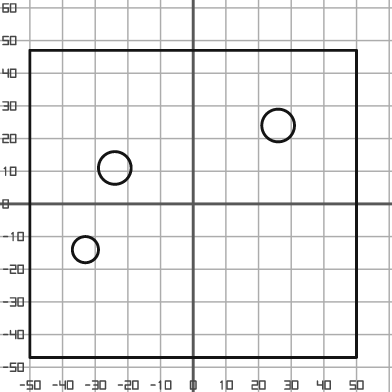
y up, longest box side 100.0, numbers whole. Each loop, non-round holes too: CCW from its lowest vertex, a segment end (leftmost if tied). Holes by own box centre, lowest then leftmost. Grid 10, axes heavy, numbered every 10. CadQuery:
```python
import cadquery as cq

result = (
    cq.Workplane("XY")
    .moveTo(-50.0, -47.0)
    .lineTo(50.0, -47.0)
    .lineTo(50.0, 47.0)
    .lineTo(-50.0, 47.0)
    .close()
    .moveTo(-33.0, -14.0)
    .circle(4.0)
    .moveTo(-24.0, 11.0)
    .circle(5.0)
    .moveTo(26.0, 24.0)
    .circle(5.0)
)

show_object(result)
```